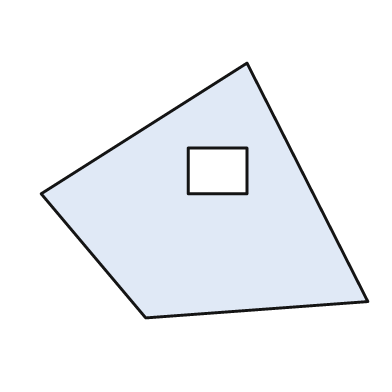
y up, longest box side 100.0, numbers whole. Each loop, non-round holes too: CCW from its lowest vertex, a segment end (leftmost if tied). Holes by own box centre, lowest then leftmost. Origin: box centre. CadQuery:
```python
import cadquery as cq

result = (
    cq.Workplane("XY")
    .moveTo(-18.0, -39.0)
    .lineTo(50.0, -34.0)
    .lineTo(13.0, 39.0)
    .lineTo(-50.0, -1.0)
    .close()
    .moveTo(-5.0, -1.0)
    .lineTo(13.0, -1.0)
    .lineTo(13.0, 13.0)
    .lineTo(-5.0, 13.0)
    .close()
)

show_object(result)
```